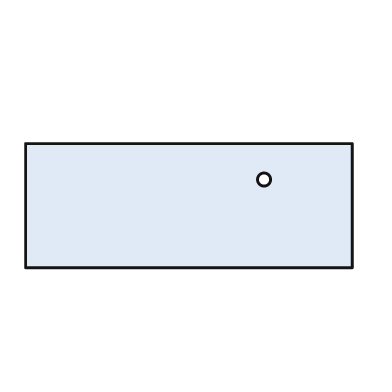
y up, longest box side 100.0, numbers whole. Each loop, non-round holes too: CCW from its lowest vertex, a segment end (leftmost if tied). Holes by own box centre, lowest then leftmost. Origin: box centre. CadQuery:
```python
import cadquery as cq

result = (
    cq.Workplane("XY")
    .moveTo(-50.0, -19.0)
    .lineTo(50.0, -19.0)
    .lineTo(50.0, 19.0)
    .lineTo(-50.0, 19.0)
    .close()
    .moveTo(23.0, 8.0)
    .circle(2.0)
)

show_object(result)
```